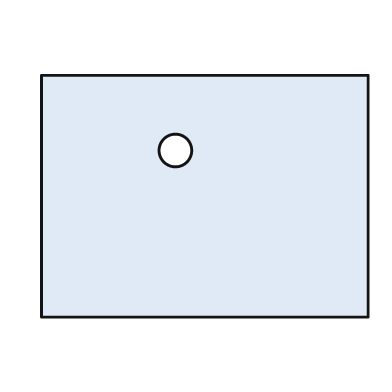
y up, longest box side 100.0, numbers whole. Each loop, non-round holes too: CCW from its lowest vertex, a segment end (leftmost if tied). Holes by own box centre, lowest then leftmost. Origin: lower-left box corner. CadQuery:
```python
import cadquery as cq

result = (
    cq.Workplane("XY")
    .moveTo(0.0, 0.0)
    .lineTo(100.0, 0.0)
    .lineTo(100.0, 74.0)
    .lineTo(0.0, 74.0)
    .close()
    .moveTo(41.0, 51.0)
    .circle(5.0)
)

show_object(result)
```